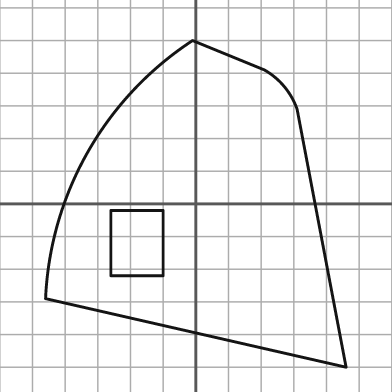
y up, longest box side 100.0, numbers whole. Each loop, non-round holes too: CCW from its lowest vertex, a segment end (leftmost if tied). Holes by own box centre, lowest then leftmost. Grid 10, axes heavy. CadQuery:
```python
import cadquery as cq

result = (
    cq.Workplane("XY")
    .moveTo(46.0, -50.0)
    .lineTo(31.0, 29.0)
    .threePointArc((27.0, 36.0), (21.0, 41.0))
    .lineTo(-1.0, 50.0)
    .threePointArc((-33.0, 16.0), (-46.0, -29.0))
    .close()
    .moveTo(-26.0, -22.0)
    .lineTo(-10.0, -22.0)
    .lineTo(-10.0, -2.0)
    .lineTo(-26.0, -2.0)
    .close()
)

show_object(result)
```